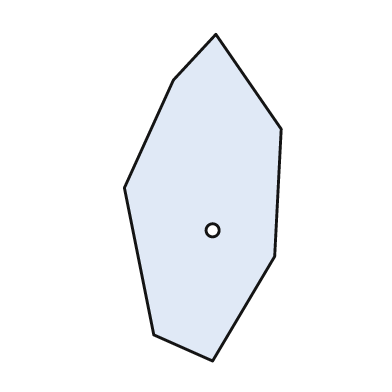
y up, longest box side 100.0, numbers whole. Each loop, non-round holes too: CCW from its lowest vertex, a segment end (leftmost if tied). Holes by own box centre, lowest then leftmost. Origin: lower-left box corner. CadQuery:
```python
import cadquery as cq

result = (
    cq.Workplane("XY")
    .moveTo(27.0, 0.0)
    .lineTo(46.0, 32.0)
    .lineTo(48.0, 71.0)
    .lineTo(28.0, 100.0)
    .lineTo(15.0, 86.0)
    .lineTo(0.0, 53.0)
    .lineTo(9.0, 8.0)
    .close()
    .moveTo(27.0, 40.0)
    .circle(2.0)
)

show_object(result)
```